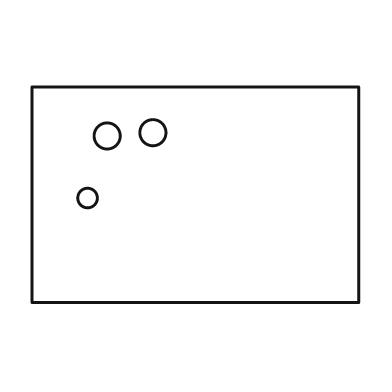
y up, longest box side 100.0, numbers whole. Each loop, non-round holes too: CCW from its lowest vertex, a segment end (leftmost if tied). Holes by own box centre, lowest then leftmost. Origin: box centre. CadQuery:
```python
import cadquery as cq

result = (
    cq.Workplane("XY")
    .moveTo(-50.0, -33.0)
    .lineTo(50.0, -33.0)
    .lineTo(50.0, 33.0)
    .lineTo(-50.0, 33.0)
    .close()
    .moveTo(-33.0, -1.0)
    .circle(3.0)
    .moveTo(-27.0, 18.0)
    .circle(4.0)
    .moveTo(-13.0, 19.0)
    .circle(4.0)
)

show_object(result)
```